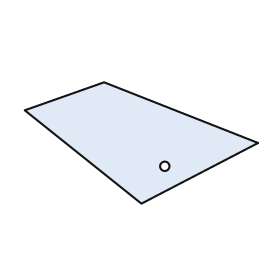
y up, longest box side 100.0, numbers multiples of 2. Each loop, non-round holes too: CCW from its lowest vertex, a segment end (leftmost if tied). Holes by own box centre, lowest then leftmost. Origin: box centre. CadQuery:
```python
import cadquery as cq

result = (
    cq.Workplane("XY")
    .moveTo(0.0, -26.0)
    .lineTo(50.0, 0.0)
    .lineTo(-16.0, 26.0)
    .lineTo(-50.0, 14.0)
    .close()
    .moveTo(10.0, -10.0)
    .circle(2.0)
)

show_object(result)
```